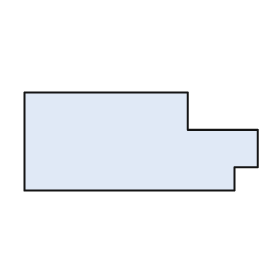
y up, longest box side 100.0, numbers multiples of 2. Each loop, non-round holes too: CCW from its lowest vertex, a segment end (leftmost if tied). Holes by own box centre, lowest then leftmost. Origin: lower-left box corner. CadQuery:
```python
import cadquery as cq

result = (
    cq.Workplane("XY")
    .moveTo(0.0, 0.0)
    .lineTo(90.0, 0.0)
    .lineTo(90.0, 10.0)
    .lineTo(100.0, 10.0)
    .lineTo(100.0, 26.0)
    .lineTo(70.0, 26.0)
    .lineTo(70.0, 42.0)
    .lineTo(0.0, 42.0)
    .close()
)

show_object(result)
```